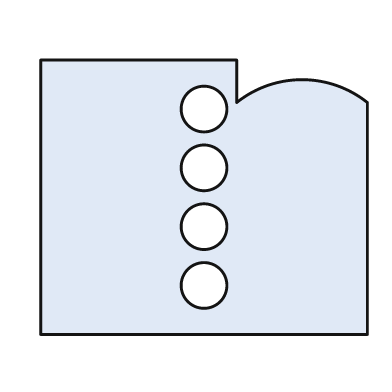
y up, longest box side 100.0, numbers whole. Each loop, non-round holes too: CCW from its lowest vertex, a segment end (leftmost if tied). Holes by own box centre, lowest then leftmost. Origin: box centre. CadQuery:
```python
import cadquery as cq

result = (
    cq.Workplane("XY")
    .moveTo(-50.0, -42.0)
    .lineTo(50.0, -42.0)
    .lineTo(50.0, 29.0)
    .threePointArc((30.0, 36.0), (10.0, 29.0))
    .lineTo(10.0, 42.0)
    .lineTo(-50.0, 42.0)
    .close()
    .moveTo(0.0, -27.0)
    .circle(7.0)
    .moveTo(0.0, -9.0)
    .circle(7.0)
    .moveTo(0.0, 9.0)
    .circle(7.0)
    .moveTo(0.0, 27.0)
    .circle(7.0)
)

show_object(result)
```